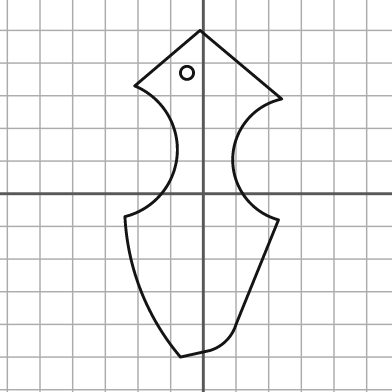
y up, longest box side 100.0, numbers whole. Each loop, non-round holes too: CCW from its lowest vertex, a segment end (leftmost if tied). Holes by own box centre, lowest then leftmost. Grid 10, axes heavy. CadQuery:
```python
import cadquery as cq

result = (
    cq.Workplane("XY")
    .moveTo(-7.0, -50.0)
    .lineTo(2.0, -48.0)
    .threePointArc((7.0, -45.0), (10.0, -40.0))
    .lineTo(23.0, -8.0)
    .threePointArc((9.0, 11.0), (24.0, 29.0))
    .lineTo(-1.0, 50.0)
    .lineTo(-21.0, 33.0)
    .threePointArc((-8.0, 12.0), (-24.0, -7.0))
    .threePointArc((-19.0, -30.0), (-7.0, -50.0))
    .close()
    .moveTo(-5.0, 37.0)
    .circle(2.0)
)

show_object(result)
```